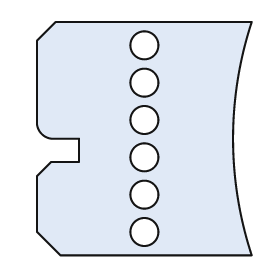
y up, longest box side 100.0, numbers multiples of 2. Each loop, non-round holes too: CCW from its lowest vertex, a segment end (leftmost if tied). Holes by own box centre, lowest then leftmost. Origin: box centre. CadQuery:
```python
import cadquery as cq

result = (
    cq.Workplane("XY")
    .moveTo(-36.0, -50.0)
    .lineTo(46.0, -50.0)
    .threePointArc((38.0, 0.0), (46.0, 50.0))
    .lineTo(-38.0, 50.0)
    .lineTo(-46.0, 42.0)
    .lineTo(-46.0, 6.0)
    .threePointArc((-44.0, 2.0), (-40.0, 0.0))
    .lineTo(-28.0, 0.0)
    .lineTo(-28.0, -10.0)
    .lineTo(-40.0, -10.0)
    .lineTo(-46.0, -16.0)
    .lineTo(-46.0, -40.0)
    .close()
    .moveTo(0.0, -40.0)
    .circle(6.0)
    .moveTo(0.0, -24.0)
    .circle(6.0)
    .moveTo(0.0, -8.0)
    .circle(6.0)
    .moveTo(0.0, 8.0)
    .circle(6.0)
    .moveTo(0.0, 24.0)
    .circle(6.0)
    .moveTo(0.0, 40.0)
    .circle(6.0)
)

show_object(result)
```